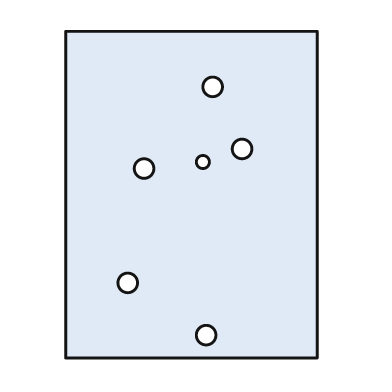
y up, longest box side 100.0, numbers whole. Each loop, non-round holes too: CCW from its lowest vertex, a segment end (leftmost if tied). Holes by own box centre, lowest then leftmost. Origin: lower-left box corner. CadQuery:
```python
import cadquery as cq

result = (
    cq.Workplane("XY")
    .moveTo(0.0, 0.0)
    .lineTo(77.0, 0.0)
    .lineTo(77.0, 100.0)
    .lineTo(0.0, 100.0)
    .close()
    .moveTo(43.0, 7.0)
    .circle(3.0)
    .moveTo(19.0, 23.0)
    .circle(3.0)
    .moveTo(24.0, 58.0)
    .circle(3.0)
    .moveTo(42.0, 60.0)
    .circle(2.0)
    .moveTo(54.0, 64.0)
    .circle(3.0)
    .moveTo(45.0, 83.0)
    .circle(3.0)
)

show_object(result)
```